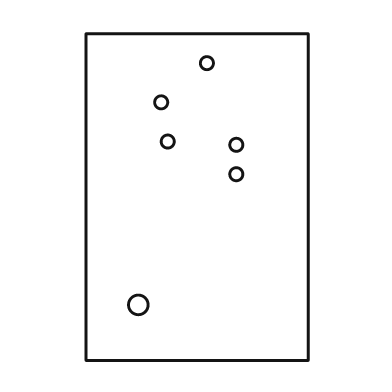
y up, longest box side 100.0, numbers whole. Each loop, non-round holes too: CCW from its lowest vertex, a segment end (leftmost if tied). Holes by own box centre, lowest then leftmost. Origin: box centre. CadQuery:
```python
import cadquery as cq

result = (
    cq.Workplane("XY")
    .moveTo(-34.0, -50.0)
    .lineTo(34.0, -50.0)
    .lineTo(34.0, 50.0)
    .lineTo(-34.0, 50.0)
    .close()
    .moveTo(-18.0, -33.0)
    .circle(3.0)
    .moveTo(12.0, 7.0)
    .circle(2.0)
    .moveTo(12.0, 16.0)
    .circle(2.0)
    .moveTo(-9.0, 17.0)
    .circle(2.0)
    .moveTo(-11.0, 29.0)
    .circle(2.0)
    .moveTo(3.0, 41.0)
    .circle(2.0)
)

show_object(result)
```